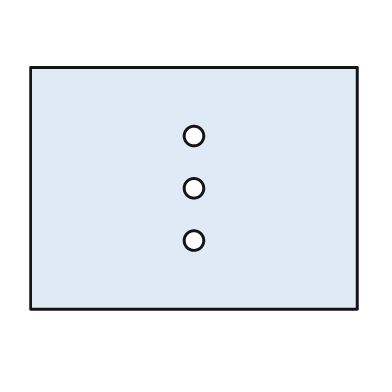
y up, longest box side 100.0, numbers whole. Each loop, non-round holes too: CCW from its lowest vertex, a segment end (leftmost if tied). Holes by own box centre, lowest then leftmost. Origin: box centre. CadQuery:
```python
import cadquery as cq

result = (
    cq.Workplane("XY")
    .moveTo(-50.0, -37.0)
    .lineTo(50.0, -37.0)
    .lineTo(50.0, 37.0)
    .lineTo(-50.0, 37.0)
    .close()
    .moveTo(0.0, -16.0)
    .circle(3.0)
    .moveTo(0.0, 0.0)
    .circle(3.0)
    .moveTo(0.0, 16.0)
    .circle(3.0)
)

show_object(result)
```